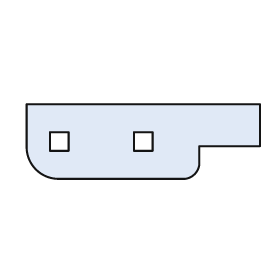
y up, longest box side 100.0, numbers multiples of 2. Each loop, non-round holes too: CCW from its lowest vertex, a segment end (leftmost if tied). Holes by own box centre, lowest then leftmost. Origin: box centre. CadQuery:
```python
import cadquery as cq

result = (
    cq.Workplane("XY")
    .moveTo(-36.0, -16.0)
    .lineTo(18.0, -16.0)
    .threePointArc((22.0, -14.0), (24.0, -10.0))
    .lineTo(24.0, -2.0)
    .lineTo(50.0, -2.0)
    .lineTo(50.0, 16.0)
    .lineTo(-50.0, 16.0)
    .lineTo(-50.0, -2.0)
    .threePointArc((-46.0, -12.0), (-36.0, -16.0))
    .close()
    .moveTo(-40.0, -4.0)
    .lineTo(-32.0, -4.0)
    .lineTo(-32.0, 4.0)
    .lineTo(-40.0, 4.0)
    .close()
    .moveTo(-4.0, -4.0)
    .lineTo(4.0, -4.0)
    .lineTo(4.0, 4.0)
    .lineTo(-4.0, 4.0)
    .close()
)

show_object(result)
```